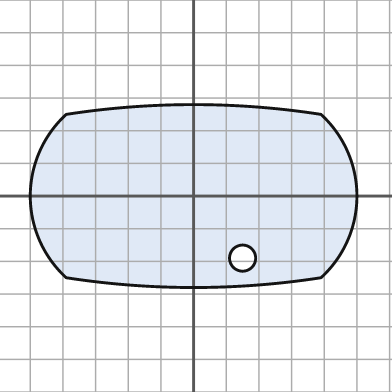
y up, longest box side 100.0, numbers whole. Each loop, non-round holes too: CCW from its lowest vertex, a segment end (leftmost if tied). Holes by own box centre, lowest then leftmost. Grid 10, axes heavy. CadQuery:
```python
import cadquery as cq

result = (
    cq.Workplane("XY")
    .moveTo(-39.0, -25.0)
    .threePointArc((0.0, -28.0), (39.0, -25.0))
    .threePointArc((50.0, 0.0), (39.0, 25.0))
    .threePointArc((0.0, 28.0), (-39.0, 25.0))
    .threePointArc((-50.0, 0.0), (-39.0, -25.0))
    .close()
    .moveTo(15.0, -19.0)
    .circle(4.0)
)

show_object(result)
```